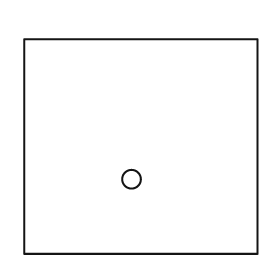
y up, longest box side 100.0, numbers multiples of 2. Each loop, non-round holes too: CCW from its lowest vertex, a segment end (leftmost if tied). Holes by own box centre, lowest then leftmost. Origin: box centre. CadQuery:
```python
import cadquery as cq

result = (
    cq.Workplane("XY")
    .moveTo(-50.0, -46.0)
    .lineTo(50.0, -46.0)
    .lineTo(50.0, 46.0)
    .lineTo(-50.0, 46.0)
    .close()
    .moveTo(-4.0, -14.0)
    .circle(4.0)
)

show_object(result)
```